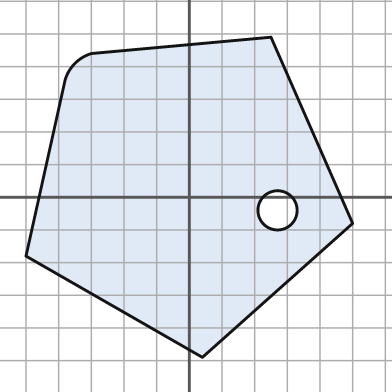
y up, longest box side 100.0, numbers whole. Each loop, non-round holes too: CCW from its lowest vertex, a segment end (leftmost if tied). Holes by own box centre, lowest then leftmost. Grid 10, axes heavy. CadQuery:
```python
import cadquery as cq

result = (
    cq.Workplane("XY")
    .moveTo(4.0, -49.0)
    .lineTo(50.0, -8.0)
    .lineTo(25.0, 49.0)
    .lineTo(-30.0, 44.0)
    .threePointArc((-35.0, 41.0), (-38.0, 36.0))
    .lineTo(-50.0, -18.0)
    .close()
    .moveTo(27.0, -4.0)
    .circle(6.0)
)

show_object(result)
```